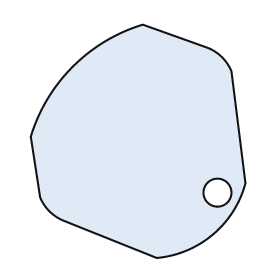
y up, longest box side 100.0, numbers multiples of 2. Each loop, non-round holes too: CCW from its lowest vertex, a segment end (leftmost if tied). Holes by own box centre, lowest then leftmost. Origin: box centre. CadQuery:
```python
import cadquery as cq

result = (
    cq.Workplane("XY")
    .moveTo(8.0, -50.0)
    .threePointArc((32.0, -40.0), (46.0, -18.0))
    .lineTo(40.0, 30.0)
    .threePointArc((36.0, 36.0), (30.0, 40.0))
    .lineTo(2.0, 50.0)
    .threePointArc((-28.0, 32.0), (-46.0, 2.0))
    .lineTo(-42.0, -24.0)
    .threePointArc((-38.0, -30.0), (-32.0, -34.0))
    .close()
    .moveTo(34.0, -22.0)
    .circle(6.0)
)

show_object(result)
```